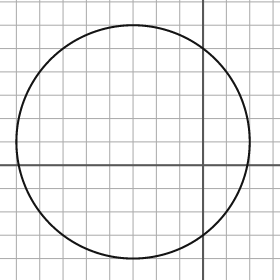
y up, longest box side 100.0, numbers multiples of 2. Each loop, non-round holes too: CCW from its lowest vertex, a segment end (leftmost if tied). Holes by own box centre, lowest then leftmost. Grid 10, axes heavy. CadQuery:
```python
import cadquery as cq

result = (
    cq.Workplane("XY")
    .moveTo(-30.0, 10.0)
    .circle(50.0)
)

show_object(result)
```